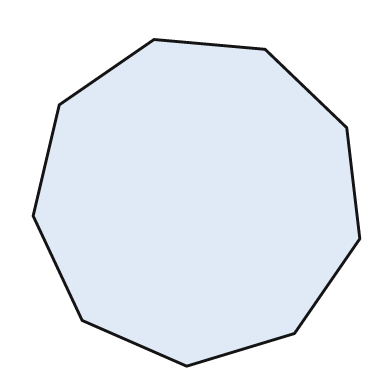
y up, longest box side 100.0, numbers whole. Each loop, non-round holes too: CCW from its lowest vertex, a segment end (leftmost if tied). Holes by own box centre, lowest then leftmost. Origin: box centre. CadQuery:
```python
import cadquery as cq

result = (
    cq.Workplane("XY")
    .moveTo(-3.0, -50.0)
    .lineTo(30.0, -40.0)
    .lineTo(50.0, -11.0)
    .lineTo(46.0, 23.0)
    .lineTo(21.0, 47.0)
    .lineTo(-13.0, 50.0)
    .lineTo(-42.0, 30.0)
    .lineTo(-50.0, -4.0)
    .lineTo(-35.0, -36.0)
    .close()
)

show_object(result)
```